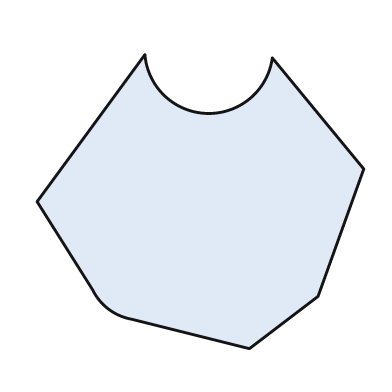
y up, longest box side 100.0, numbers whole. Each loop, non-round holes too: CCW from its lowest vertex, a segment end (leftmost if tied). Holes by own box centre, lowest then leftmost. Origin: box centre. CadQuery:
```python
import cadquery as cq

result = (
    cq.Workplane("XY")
    .moveTo(15.0, -45.0)
    .lineTo(36.0, -29.0)
    .lineTo(50.0, 10.0)
    .lineTo(22.0, 44.0)
    .threePointArc((2.0, 27.0), (-17.0, 45.0))
    .lineTo(-50.0, 0.0)
    .lineTo(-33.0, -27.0)
    .threePointArc((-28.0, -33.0), (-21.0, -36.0))
    .close()
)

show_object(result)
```